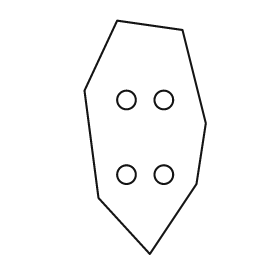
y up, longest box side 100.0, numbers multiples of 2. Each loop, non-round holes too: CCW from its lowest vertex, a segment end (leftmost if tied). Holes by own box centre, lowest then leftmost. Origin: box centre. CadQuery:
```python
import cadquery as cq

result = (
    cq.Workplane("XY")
    .moveTo(2.0, -50.0)
    .lineTo(22.0, -20.0)
    .lineTo(26.0, 6.0)
    .lineTo(16.0, 46.0)
    .lineTo(-12.0, 50.0)
    .lineTo(-26.0, 20.0)
    .lineTo(-20.0, -26.0)
    .close()
    .moveTo(-8.0, -16.0)
    .circle(4.0)
    .moveTo(8.0, -16.0)
    .circle(4.0)
    .moveTo(-8.0, 16.0)
    .circle(4.0)
    .moveTo(8.0, 16.0)
    .circle(4.0)
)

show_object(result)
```